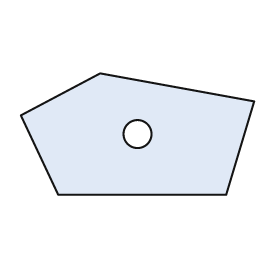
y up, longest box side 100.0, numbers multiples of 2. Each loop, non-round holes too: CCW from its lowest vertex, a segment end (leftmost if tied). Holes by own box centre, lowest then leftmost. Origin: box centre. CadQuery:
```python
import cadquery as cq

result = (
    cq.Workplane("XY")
    .moveTo(-34.0, -26.0)
    .lineTo(38.0, -26.0)
    .lineTo(50.0, 14.0)
    .lineTo(-16.0, 26.0)
    .lineTo(-50.0, 8.0)
    .close()
    .moveTo(0.0, 0.0)
    .circle(6.0)
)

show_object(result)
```